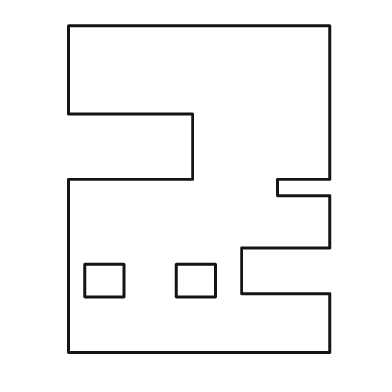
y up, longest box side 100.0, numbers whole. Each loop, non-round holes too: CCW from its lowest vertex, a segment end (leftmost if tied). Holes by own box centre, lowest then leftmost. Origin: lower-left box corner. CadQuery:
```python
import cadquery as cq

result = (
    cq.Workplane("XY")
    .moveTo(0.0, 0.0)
    .lineTo(80.0, 0.0)
    .lineTo(80.0, 18.0)
    .lineTo(53.0, 18.0)
    .lineTo(53.0, 32.0)
    .lineTo(80.0, 32.0)
    .lineTo(80.0, 48.0)
    .lineTo(64.0, 48.0)
    .lineTo(64.0, 53.0)
    .lineTo(80.0, 53.0)
    .lineTo(80.0, 100.0)
    .lineTo(0.0, 100.0)
    .lineTo(0.0, 73.0)
    .lineTo(38.0, 73.0)
    .lineTo(38.0, 53.0)
    .lineTo(0.0, 53.0)
    .close()
    .moveTo(5.0, 17.0)
    .lineTo(17.0, 17.0)
    .lineTo(17.0, 27.0)
    .lineTo(5.0, 27.0)
    .close()
    .moveTo(33.0, 17.0)
    .lineTo(45.0, 17.0)
    .lineTo(45.0, 27.0)
    .lineTo(33.0, 27.0)
    .close()
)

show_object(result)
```